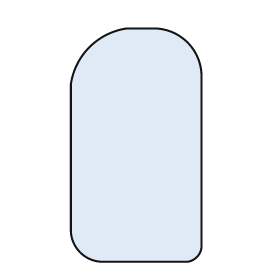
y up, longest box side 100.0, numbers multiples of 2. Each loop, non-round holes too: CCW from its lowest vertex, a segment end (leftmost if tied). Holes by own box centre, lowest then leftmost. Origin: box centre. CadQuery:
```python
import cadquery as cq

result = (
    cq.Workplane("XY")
    .moveTo(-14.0, -50.0)
    .lineTo(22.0, -50.0)
    .threePointArc((26.0, -48.0), (28.0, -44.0))
    .lineTo(28.0, 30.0)
    .threePointArc((22.0, 44.0), (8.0, 50.0))
    .lineTo(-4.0, 50.0)
    .threePointArc((-20.0, 42.0), (-28.0, 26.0))
    .lineTo(-28.0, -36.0)
    .threePointArc((-24.0, -46.0), (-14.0, -50.0))
    .close()
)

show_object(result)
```